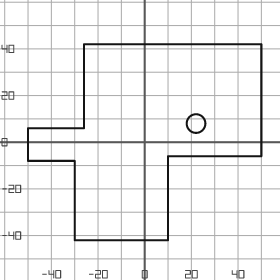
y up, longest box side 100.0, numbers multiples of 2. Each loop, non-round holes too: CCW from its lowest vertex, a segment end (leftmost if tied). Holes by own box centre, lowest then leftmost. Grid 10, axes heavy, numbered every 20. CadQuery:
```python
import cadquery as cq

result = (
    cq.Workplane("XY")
    .moveTo(-30.0, -42.0)
    .lineTo(10.0, -42.0)
    .lineTo(10.0, -6.0)
    .lineTo(50.0, -6.0)
    .lineTo(50.0, 42.0)
    .lineTo(-26.0, 42.0)
    .lineTo(-26.0, 6.0)
    .lineTo(-50.0, 6.0)
    .lineTo(-50.0, -8.0)
    .lineTo(-30.0, -8.0)
    .close()
    .moveTo(22.0, 8.0)
    .circle(4.0)
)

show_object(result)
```